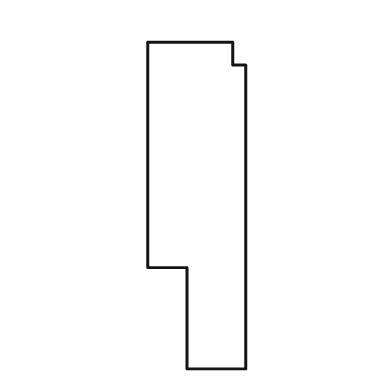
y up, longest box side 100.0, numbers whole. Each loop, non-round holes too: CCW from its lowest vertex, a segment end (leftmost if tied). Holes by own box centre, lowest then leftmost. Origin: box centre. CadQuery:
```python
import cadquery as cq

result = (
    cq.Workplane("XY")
    .moveTo(-3.0, -50.0)
    .lineTo(15.0, -50.0)
    .lineTo(15.0, 43.0)
    .lineTo(11.0, 43.0)
    .lineTo(11.0, 50.0)
    .lineTo(-15.0, 50.0)
    .lineTo(-15.0, -19.0)
    .lineTo(-3.0, -19.0)
    .close()
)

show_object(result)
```